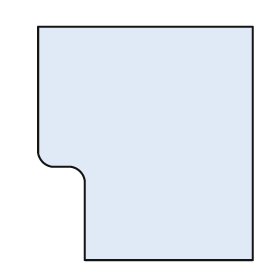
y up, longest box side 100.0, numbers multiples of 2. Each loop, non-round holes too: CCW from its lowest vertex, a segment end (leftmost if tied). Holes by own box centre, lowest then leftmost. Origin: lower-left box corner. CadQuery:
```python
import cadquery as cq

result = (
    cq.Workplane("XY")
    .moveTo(20.0, 0.0)
    .lineTo(92.0, 0.0)
    .lineTo(92.0, 100.0)
    .lineTo(0.0, 100.0)
    .lineTo(0.0, 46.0)
    .threePointArc((2.0, 42.0), (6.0, 40.0))
    .lineTo(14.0, 40.0)
    .threePointArc((18.0, 38.0), (20.0, 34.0))
    .close()
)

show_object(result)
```